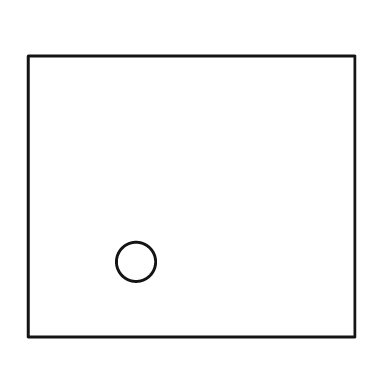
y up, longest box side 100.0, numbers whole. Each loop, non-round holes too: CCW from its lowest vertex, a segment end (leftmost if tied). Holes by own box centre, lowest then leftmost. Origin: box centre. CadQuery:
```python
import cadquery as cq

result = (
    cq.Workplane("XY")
    .moveTo(-50.0, -43.0)
    .lineTo(50.0, -43.0)
    .lineTo(50.0, 43.0)
    .lineTo(-50.0, 43.0)
    .close()
    .moveTo(-17.0, -20.0)
    .circle(6.0)
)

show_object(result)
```